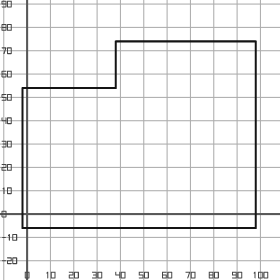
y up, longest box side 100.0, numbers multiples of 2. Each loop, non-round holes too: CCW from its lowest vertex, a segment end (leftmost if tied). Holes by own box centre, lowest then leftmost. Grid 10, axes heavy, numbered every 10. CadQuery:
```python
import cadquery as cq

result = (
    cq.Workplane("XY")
    .moveTo(-2.0, -6.0)
    .lineTo(98.0, -6.0)
    .lineTo(98.0, 74.0)
    .lineTo(38.0, 74.0)
    .lineTo(38.0, 54.0)
    .lineTo(-2.0, 54.0)
    .close()
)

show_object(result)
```